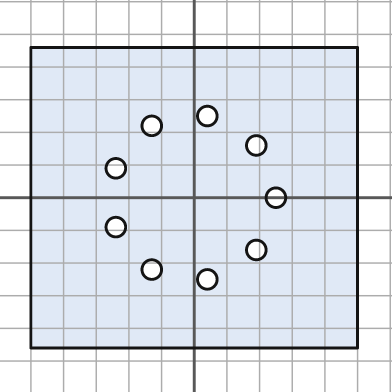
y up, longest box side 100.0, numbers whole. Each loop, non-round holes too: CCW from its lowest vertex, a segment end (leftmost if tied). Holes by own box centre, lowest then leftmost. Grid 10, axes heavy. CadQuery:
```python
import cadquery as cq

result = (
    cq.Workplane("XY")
    .moveTo(-50.0, -46.0)
    .lineTo(50.0, -46.0)
    .lineTo(50.0, 46.0)
    .lineTo(-50.0, 46.0)
    .close()
    .moveTo(4.0, -25.0)
    .circle(3.0)
    .moveTo(-13.0, -22.0)
    .circle(3.0)
    .moveTo(19.0, -16.0)
    .circle(3.0)
    .moveTo(-24.0, -9.0)
    .circle(3.0)
    .moveTo(25.0, 0.0)
    .circle(3.0)
    .moveTo(-24.0, 9.0)
    .circle(3.0)
    .moveTo(19.0, 16.0)
    .circle(3.0)
    .moveTo(-13.0, 22.0)
    .circle(3.0)
    .moveTo(4.0, 25.0)
    .circle(3.0)
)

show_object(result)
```